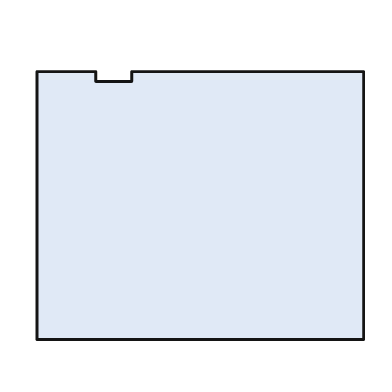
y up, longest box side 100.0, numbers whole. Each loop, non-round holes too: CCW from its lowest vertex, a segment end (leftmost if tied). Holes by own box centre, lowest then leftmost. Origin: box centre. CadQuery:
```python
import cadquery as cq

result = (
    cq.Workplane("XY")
    .moveTo(-50.0, -41.0)
    .lineTo(50.0, -41.0)
    .lineTo(50.0, 41.0)
    .lineTo(-21.0, 41.0)
    .lineTo(-21.0, 38.0)
    .lineTo(-32.0, 38.0)
    .lineTo(-32.0, 41.0)
    .lineTo(-50.0, 41.0)
    .close()
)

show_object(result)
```